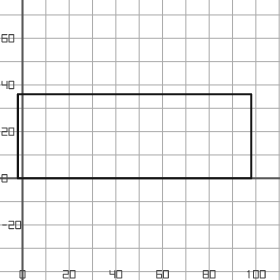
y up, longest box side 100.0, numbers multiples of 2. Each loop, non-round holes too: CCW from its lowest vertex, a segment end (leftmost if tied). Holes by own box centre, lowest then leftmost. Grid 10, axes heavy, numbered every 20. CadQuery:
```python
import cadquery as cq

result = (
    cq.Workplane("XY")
    .moveTo(-2.0, 0.0)
    .lineTo(98.0, 0.0)
    .lineTo(98.0, 36.0)
    .lineTo(-2.0, 36.0)
    .close()
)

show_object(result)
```